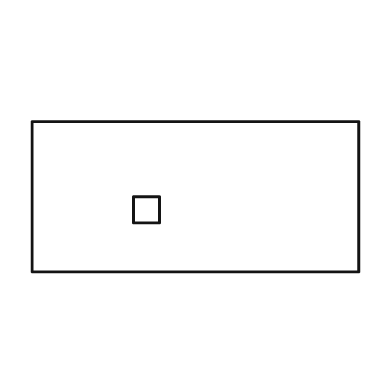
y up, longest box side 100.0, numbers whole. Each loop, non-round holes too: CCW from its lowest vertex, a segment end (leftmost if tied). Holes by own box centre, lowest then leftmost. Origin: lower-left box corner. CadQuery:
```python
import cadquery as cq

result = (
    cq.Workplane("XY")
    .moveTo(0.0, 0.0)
    .lineTo(100.0, 0.0)
    .lineTo(100.0, 46.0)
    .lineTo(0.0, 46.0)
    .close()
    .moveTo(31.0, 15.0)
    .lineTo(39.0, 15.0)
    .lineTo(39.0, 23.0)
    .lineTo(31.0, 23.0)
    .close()
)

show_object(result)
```